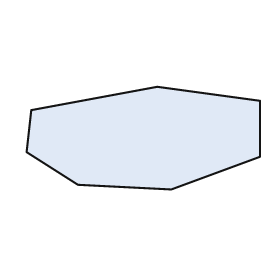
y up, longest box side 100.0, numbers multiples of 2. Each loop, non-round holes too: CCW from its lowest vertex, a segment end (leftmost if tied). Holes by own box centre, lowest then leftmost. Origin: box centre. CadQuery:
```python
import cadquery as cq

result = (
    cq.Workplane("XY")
    .moveTo(12.0, -22.0)
    .lineTo(50.0, -8.0)
    .lineTo(50.0, 16.0)
    .lineTo(6.0, 22.0)
    .lineTo(-48.0, 12.0)
    .lineTo(-50.0, -6.0)
    .lineTo(-28.0, -20.0)
    .close()
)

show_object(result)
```